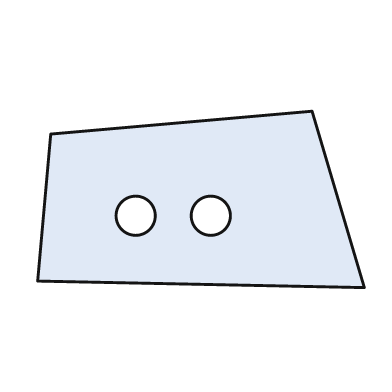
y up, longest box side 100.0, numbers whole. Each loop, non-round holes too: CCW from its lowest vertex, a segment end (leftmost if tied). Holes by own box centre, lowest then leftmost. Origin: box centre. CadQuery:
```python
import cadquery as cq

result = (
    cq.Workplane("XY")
    .moveTo(50.0, -27.0)
    .lineTo(34.0, 27.0)
    .lineTo(-46.0, 20.0)
    .lineTo(-50.0, -25.0)
    .close()
    .moveTo(-20.0, -5.0)
    .circle(6.0)
    .moveTo(3.0, -5.0)
    .circle(6.0)
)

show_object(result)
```